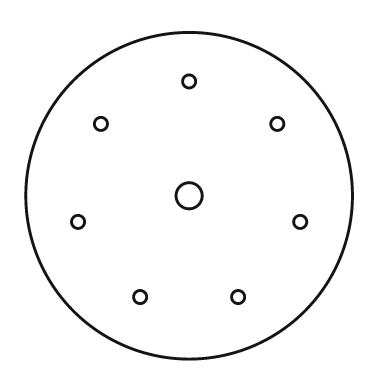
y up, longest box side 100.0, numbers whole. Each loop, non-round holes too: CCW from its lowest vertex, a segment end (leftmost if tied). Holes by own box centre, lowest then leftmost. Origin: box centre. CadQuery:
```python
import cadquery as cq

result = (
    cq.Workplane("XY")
    .moveTo(0.0, 0.0)
    .circle(50.0)
    .moveTo(-15.0, -31.0)
    .circle(2.0)
    .moveTo(15.0, -31.0)
    .circle(2.0)
    .moveTo(-34.0, -8.0)
    .circle(2.0)
    .moveTo(34.0, -8.0)
    .circle(2.0)
    .moveTo(0.0, 0.0)
    .circle(4.0)
    .moveTo(-27.0, 22.0)
    .circle(2.0)
    .moveTo(27.0, 22.0)
    .circle(2.0)
    .moveTo(0.0, 35.0)
    .circle(2.0)
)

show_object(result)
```